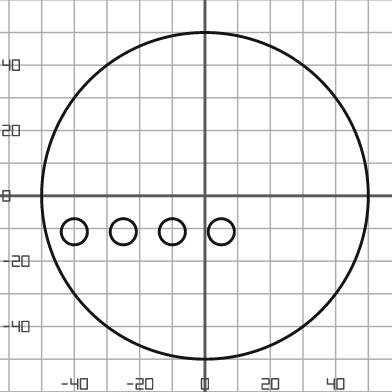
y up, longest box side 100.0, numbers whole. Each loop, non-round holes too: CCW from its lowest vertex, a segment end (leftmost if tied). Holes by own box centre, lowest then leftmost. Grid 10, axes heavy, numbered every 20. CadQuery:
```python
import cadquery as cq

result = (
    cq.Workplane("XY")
    .moveTo(0.0, 0.0)
    .circle(50.0)
    .moveTo(-40.0, -11.0)
    .circle(4.0)
    .moveTo(-25.0, -11.0)
    .circle(4.0)
    .moveTo(-10.0, -11.0)
    .circle(4.0)
    .moveTo(5.0, -11.0)
    .circle(4.0)
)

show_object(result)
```